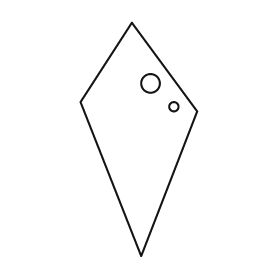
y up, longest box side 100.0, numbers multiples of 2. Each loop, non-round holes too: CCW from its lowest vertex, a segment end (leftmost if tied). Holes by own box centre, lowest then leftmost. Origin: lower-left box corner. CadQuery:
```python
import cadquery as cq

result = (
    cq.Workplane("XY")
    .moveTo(26.0, 0.0)
    .lineTo(50.0, 62.0)
    .lineTo(22.0, 100.0)
    .lineTo(0.0, 66.0)
    .close()
    .moveTo(40.0, 64.0)
    .circle(2.0)
    .moveTo(30.0, 74.0)
    .circle(4.0)
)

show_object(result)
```